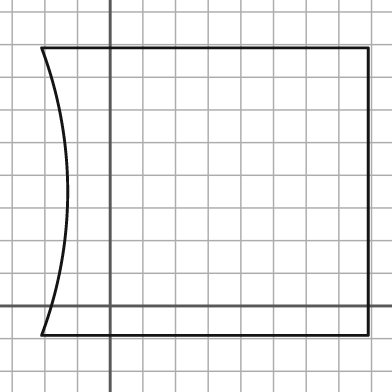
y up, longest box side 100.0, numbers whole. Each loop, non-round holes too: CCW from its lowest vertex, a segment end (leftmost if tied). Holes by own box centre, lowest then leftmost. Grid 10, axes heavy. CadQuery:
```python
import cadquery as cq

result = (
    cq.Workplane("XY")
    .moveTo(-21.0, -9.0)
    .lineTo(79.0, -9.0)
    .lineTo(79.0, 79.0)
    .lineTo(-21.0, 79.0)
    .threePointArc((-13.0, 35.0), (-21.0, -9.0))
    .close()
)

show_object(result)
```